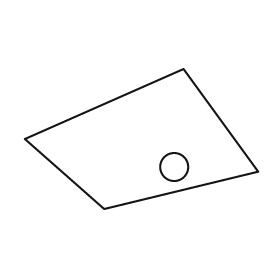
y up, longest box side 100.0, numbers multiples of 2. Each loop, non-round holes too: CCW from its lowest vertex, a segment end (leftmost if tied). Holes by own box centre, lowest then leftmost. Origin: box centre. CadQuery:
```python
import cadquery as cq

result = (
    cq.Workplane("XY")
    .moveTo(-16.0, -30.0)
    .lineTo(50.0, -14.0)
    .lineTo(18.0, 30.0)
    .lineTo(-50.0, 0.0)
    .close()
    .moveTo(14.0, -12.0)
    .circle(6.0)
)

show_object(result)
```